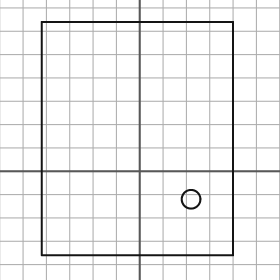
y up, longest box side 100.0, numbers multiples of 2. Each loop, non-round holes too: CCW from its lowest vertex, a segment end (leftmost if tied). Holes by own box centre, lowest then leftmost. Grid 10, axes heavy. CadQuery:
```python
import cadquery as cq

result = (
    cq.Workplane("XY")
    .moveTo(-42.0, -36.0)
    .lineTo(40.0, -36.0)
    .lineTo(40.0, 64.0)
    .lineTo(-42.0, 64.0)
    .close()
    .moveTo(22.0, -12.0)
    .circle(4.0)
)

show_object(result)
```